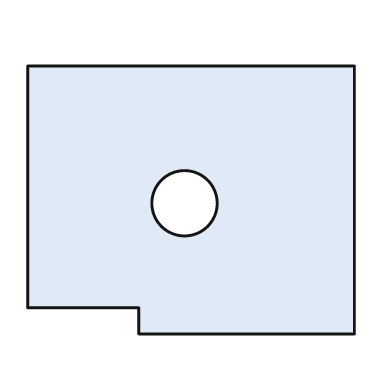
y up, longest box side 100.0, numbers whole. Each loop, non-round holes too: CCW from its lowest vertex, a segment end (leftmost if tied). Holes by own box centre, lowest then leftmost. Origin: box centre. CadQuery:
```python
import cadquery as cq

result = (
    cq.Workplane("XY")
    .moveTo(-16.0, -41.0)
    .lineTo(50.0, -41.0)
    .lineTo(50.0, 41.0)
    .lineTo(-50.0, 41.0)
    .lineTo(-50.0, -33.0)
    .lineTo(-16.0, -33.0)
    .close()
    .moveTo(-2.0, -1.0)
    .circle(10.0)
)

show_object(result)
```